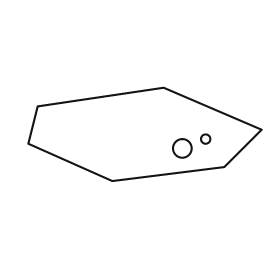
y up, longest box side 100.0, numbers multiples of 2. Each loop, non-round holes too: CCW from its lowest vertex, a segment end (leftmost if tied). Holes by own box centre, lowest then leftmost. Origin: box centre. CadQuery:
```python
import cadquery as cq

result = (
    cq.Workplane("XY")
    .moveTo(-14.0, -20.0)
    .lineTo(34.0, -14.0)
    .lineTo(50.0, 2.0)
    .lineTo(8.0, 20.0)
    .lineTo(-46.0, 12.0)
    .lineTo(-50.0, -4.0)
    .close()
    .moveTo(16.0, -6.0)
    .circle(4.0)
    .moveTo(26.0, -2.0)
    .circle(2.0)
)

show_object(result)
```